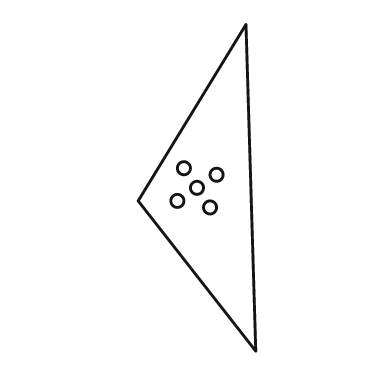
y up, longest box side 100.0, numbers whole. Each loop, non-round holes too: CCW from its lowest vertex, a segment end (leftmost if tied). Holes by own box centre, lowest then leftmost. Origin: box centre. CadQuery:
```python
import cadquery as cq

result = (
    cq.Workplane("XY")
    .moveTo(18.0, -50.0)
    .lineTo(15.0, 50.0)
    .lineTo(-18.0, -4.0)
    .close()
    .moveTo(4.0, -6.0)
    .circle(2.0)
    .moveTo(-6.0, -4.0)
    .circle(2.0)
    .moveTo(0.0, 0.0)
    .circle(2.0)
    .moveTo(6.0, 4.0)
    .circle(2.0)
    .moveTo(-4.0, 6.0)
    .circle(2.0)
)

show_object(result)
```